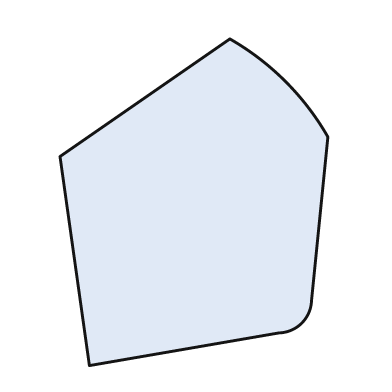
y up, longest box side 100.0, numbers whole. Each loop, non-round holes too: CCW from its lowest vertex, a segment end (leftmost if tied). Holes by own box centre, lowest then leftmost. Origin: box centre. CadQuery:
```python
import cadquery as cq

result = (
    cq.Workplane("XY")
    .moveTo(-32.0, -50.0)
    .lineTo(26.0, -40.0)
    .threePointArc((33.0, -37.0), (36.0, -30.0))
    .lineTo(41.0, 20.0)
    .threePointArc((28.0, 37.0), (11.0, 50.0))
    .lineTo(-41.0, 14.0)
    .close()
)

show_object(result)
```